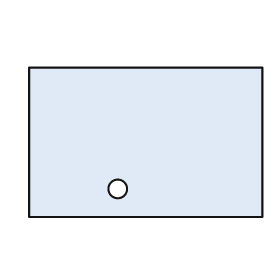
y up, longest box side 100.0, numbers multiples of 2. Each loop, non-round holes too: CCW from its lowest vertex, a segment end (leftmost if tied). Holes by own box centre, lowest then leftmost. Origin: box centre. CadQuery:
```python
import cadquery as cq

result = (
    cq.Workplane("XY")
    .moveTo(-50.0, -32.0)
    .lineTo(50.0, -32.0)
    .lineTo(50.0, 32.0)
    .lineTo(-50.0, 32.0)
    .close()
    .moveTo(-12.0, -20.0)
    .circle(4.0)
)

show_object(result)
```